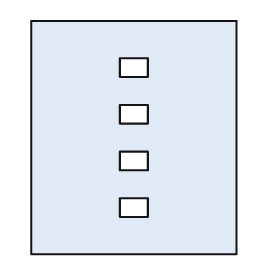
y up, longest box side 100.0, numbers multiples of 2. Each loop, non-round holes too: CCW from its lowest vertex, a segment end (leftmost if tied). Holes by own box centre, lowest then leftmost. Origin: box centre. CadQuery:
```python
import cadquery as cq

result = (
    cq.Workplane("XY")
    .moveTo(-44.0, -50.0)
    .lineTo(44.0, -50.0)
    .lineTo(44.0, 50.0)
    .lineTo(-44.0, 50.0)
    .close()
    .moveTo(-6.0, -34.0)
    .lineTo(6.0, -34.0)
    .lineTo(6.0, -26.0)
    .lineTo(-6.0, -26.0)
    .close()
    .moveTo(-6.0, -14.0)
    .lineTo(6.0, -14.0)
    .lineTo(6.0, -6.0)
    .lineTo(-6.0, -6.0)
    .close()
    .moveTo(-6.0, 6.0)
    .lineTo(6.0, 6.0)
    .lineTo(6.0, 14.0)
    .lineTo(-6.0, 14.0)
    .close()
    .moveTo(-6.0, 26.0)
    .lineTo(6.0, 26.0)
    .lineTo(6.0, 34.0)
    .lineTo(-6.0, 34.0)
    .close()
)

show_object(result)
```